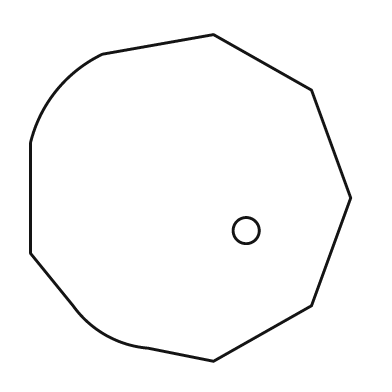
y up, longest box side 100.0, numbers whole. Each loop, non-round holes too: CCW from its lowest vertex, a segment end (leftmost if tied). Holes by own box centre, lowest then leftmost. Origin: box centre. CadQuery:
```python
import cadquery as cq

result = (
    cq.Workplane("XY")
    .moveTo(7.0, -50.0)
    .lineTo(37.0, -33.0)
    .lineTo(49.0, 0.0)
    .lineTo(37.0, 33.0)
    .lineTo(7.0, 50.0)
    .lineTo(-27.0, 44.0)
    .threePointArc((-41.0, 33.0), (-49.0, 17.0))
    .lineTo(-49.0, -17.0)
    .lineTo(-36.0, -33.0)
    .threePointArc((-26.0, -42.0), (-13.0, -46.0))
    .close()
    .moveTo(17.0, -10.0)
    .circle(4.0)
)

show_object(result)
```